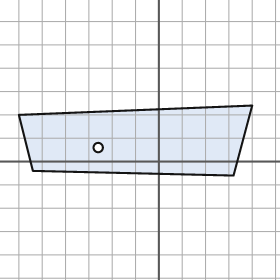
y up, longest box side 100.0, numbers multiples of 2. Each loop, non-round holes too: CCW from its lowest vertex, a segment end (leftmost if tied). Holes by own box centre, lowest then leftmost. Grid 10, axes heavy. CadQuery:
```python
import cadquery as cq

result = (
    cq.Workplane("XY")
    .moveTo(32.0, -6.0)
    .lineTo(40.0, 24.0)
    .lineTo(-60.0, 20.0)
    .lineTo(-54.0, -4.0)
    .close()
    .moveTo(-26.0, 6.0)
    .circle(2.0)
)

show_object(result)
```